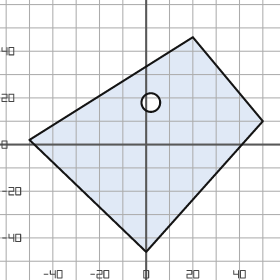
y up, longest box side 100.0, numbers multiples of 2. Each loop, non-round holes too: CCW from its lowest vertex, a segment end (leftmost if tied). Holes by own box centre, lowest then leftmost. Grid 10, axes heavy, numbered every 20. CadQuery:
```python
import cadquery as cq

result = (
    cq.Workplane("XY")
    .moveTo(0.0, -46.0)
    .lineTo(50.0, 10.0)
    .lineTo(20.0, 46.0)
    .lineTo(-50.0, 2.0)
    .close()
    .moveTo(2.0, 18.0)
    .circle(4.0)
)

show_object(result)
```